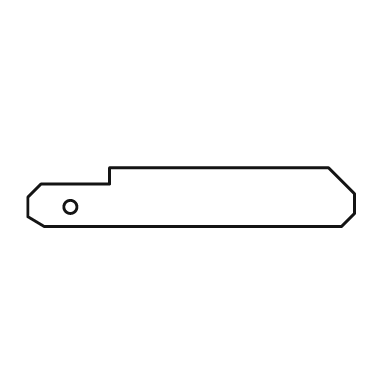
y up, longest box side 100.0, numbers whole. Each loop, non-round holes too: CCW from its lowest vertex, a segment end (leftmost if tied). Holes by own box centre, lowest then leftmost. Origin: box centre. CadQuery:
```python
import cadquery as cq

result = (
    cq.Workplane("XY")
    .moveTo(-45.0, -9.0)
    .lineTo(46.0, -9.0)
    .lineTo(50.0, -5.0)
    .lineTo(50.0, 1.0)
    .lineTo(42.0, 9.0)
    .lineTo(-25.0, 9.0)
    .lineTo(-25.0, 4.0)
    .lineTo(-46.0, 4.0)
    .lineTo(-50.0, 0.0)
    .lineTo(-50.0, -6.0)
    .close()
    .moveTo(-37.0, -3.0)
    .circle(2.0)
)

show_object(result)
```